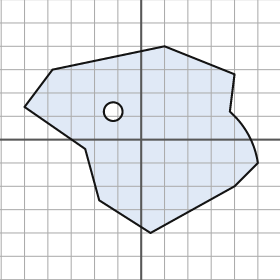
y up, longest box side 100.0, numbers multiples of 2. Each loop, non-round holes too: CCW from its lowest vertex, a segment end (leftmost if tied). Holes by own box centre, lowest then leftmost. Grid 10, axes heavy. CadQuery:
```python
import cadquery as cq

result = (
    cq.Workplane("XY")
    .moveTo(4.0, -40.0)
    .lineTo(40.0, -20.0)
    .lineTo(50.0, -10.0)
    .threePointArc((46.0, 2.0), (38.0, 12.0))
    .lineTo(40.0, 28.0)
    .lineTo(10.0, 40.0)
    .lineTo(-38.0, 30.0)
    .lineTo(-50.0, 14.0)
    .lineTo(-24.0, -4.0)
    .lineTo(-18.0, -26.0)
    .close()
    .moveTo(-12.0, 12.0)
    .circle(4.0)
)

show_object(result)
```